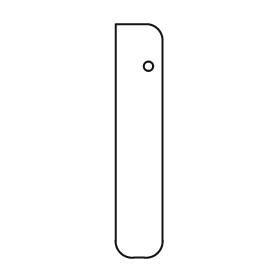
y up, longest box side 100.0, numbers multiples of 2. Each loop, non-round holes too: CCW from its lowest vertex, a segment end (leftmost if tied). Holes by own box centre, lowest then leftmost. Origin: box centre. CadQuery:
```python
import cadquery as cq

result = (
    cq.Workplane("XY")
    .moveTo(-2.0, -50.0)
    .lineTo(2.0, -50.0)
    .threePointArc((8.0, -48.0), (10.0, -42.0))
    .lineTo(10.0, 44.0)
    .threePointArc((8.0, 48.0), (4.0, 50.0))
    .lineTo(-10.0, 50.0)
    .lineTo(-10.0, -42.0)
    .threePointArc((-8.0, -48.0), (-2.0, -50.0))
    .close()
    .moveTo(4.0, 32.0)
    .circle(2.0)
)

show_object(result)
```